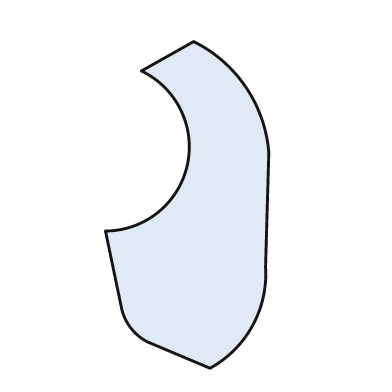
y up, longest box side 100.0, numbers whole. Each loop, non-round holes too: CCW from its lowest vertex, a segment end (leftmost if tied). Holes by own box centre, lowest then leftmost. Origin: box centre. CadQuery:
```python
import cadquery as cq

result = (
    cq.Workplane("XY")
    .moveTo(7.0, -50.0)
    .threePointArc((20.0, -37.0), (24.0, -19.0))
    .lineTo(25.0, 16.0)
    .threePointArc((18.0, 36.0), (2.0, 50.0))
    .lineTo(-14.0, 41.0)
    .threePointArc((0.0, 12.0), (-25.0, -8.0))
    .lineTo(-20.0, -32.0)
    .threePointArc((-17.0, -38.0), (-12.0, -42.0))
    .close()
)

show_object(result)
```